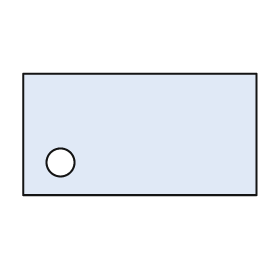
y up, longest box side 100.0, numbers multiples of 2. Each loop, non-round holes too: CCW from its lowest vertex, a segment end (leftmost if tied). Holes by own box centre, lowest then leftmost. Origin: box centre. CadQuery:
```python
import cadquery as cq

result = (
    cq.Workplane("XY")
    .moveTo(-50.0, -26.0)
    .lineTo(50.0, -26.0)
    .lineTo(50.0, 26.0)
    .lineTo(-50.0, 26.0)
    .close()
    .moveTo(-34.0, -12.0)
    .circle(6.0)
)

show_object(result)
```